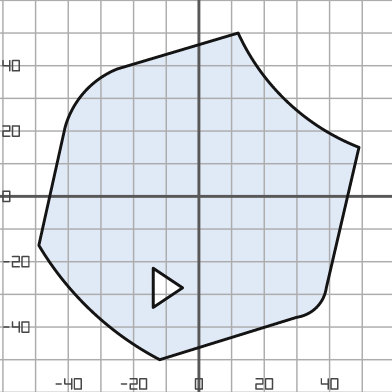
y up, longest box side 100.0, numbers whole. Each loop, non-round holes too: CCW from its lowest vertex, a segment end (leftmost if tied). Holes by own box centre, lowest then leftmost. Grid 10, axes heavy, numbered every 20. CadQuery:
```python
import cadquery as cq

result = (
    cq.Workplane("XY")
    .moveTo(-12.0, -50.0)
    .lineTo(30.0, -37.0)
    .threePointArc((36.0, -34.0), (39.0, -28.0))
    .lineTo(49.0, 15.0)
    .threePointArc((27.0, 29.0), (12.0, 50.0))
    .lineTo(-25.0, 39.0)
    .threePointArc((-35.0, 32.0), (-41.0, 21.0))
    .lineTo(-49.0, -15.0)
    .threePointArc((-33.0, -35.0), (-12.0, -50.0))
    .close()
    .moveTo(-14.0, -34.0)
    .lineTo(-5.0, -28.0)
    .lineTo(-14.0, -22.0)
    .close()
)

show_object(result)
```